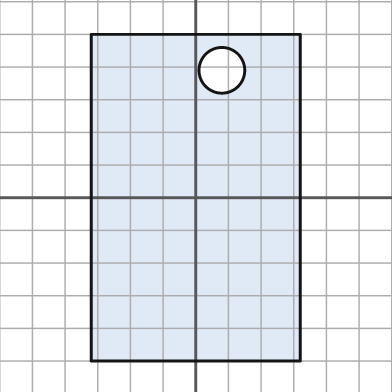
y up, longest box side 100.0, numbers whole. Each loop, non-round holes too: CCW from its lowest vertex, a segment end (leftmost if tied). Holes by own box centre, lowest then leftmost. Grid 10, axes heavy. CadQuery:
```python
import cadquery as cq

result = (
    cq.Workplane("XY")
    .moveTo(-32.0, -50.0)
    .lineTo(32.0, -50.0)
    .lineTo(32.0, 50.0)
    .lineTo(-32.0, 50.0)
    .close()
    .moveTo(8.0, 39.0)
    .circle(7.0)
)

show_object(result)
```